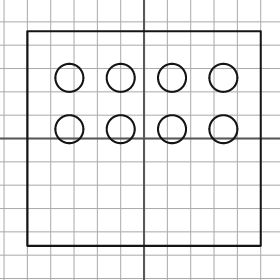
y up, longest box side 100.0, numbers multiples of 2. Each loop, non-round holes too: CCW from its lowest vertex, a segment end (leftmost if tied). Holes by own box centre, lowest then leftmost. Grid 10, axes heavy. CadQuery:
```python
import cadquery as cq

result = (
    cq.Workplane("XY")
    .moveTo(-50.0, -46.0)
    .lineTo(50.0, -46.0)
    .lineTo(50.0, 46.0)
    .lineTo(-50.0, 46.0)
    .close()
    .moveTo(-32.0, 4.0)
    .circle(6.0)
    .moveTo(-10.0, 4.0)
    .circle(6.0)
    .moveTo(12.0, 4.0)
    .circle(6.0)
    .moveTo(34.0, 4.0)
    .circle(6.0)
    .moveTo(-32.0, 26.0)
    .circle(6.0)
    .moveTo(-10.0, 26.0)
    .circle(6.0)
    .moveTo(12.0, 26.0)
    .circle(6.0)
    .moveTo(34.0, 26.0)
    .circle(6.0)
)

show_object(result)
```